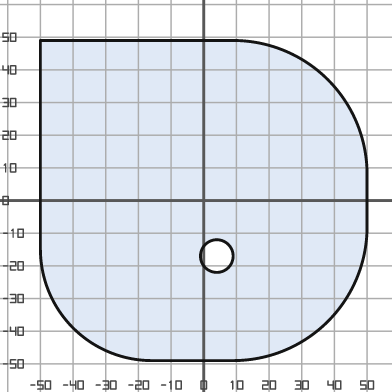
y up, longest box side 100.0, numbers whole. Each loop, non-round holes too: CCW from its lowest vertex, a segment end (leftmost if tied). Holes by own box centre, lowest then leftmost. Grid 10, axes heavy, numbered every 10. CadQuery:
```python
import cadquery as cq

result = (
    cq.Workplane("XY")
    .moveTo(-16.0, -49.0)
    .lineTo(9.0, -49.0)
    .threePointArc((38.0, -37.0), (50.0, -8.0))
    .lineTo(50.0, 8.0)
    .threePointArc((38.0, 37.0), (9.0, 49.0))
    .lineTo(-50.0, 49.0)
    .lineTo(-50.0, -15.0)
    .threePointArc((-40.0, -39.0), (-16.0, -49.0))
    .close()
    .moveTo(4.0, -17.0)
    .circle(5.0)
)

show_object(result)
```